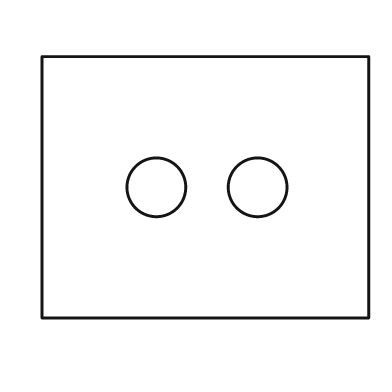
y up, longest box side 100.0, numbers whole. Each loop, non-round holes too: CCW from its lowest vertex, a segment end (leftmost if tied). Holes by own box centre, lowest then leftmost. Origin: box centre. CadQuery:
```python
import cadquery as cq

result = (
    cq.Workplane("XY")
    .moveTo(-50.0, -40.0)
    .lineTo(50.0, -40.0)
    .lineTo(50.0, 40.0)
    .lineTo(-50.0, 40.0)
    .close()
    .moveTo(-15.0, 0.0)
    .circle(9.0)
    .moveTo(16.0, 0.0)
    .circle(9.0)
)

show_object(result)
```